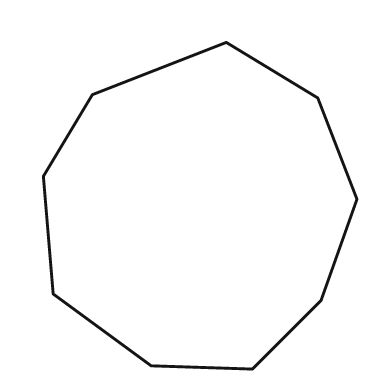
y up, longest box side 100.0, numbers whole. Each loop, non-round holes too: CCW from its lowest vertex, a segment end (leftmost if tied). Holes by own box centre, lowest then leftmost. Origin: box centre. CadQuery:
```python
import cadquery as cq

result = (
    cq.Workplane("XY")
    .moveTo(16.0, -50.0)
    .lineTo(37.0, -29.0)
    .lineTo(48.0, 2.0)
    .lineTo(36.0, 33.0)
    .lineTo(8.0, 50.0)
    .lineTo(-33.0, 34.0)
    .lineTo(-48.0, 9.0)
    .lineTo(-45.0, -27.0)
    .lineTo(-15.0, -49.0)
    .close()
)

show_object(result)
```